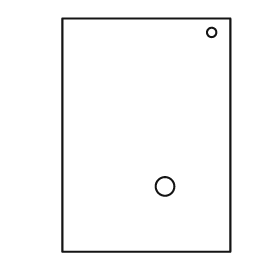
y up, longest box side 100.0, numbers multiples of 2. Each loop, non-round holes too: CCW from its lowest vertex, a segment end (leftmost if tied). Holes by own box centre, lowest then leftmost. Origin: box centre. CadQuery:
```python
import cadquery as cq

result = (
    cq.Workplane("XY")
    .moveTo(-36.0, -50.0)
    .lineTo(36.0, -50.0)
    .lineTo(36.0, 50.0)
    .lineTo(-36.0, 50.0)
    .close()
    .moveTo(8.0, -22.0)
    .circle(4.0)
    .moveTo(28.0, 44.0)
    .circle(2.0)
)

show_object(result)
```